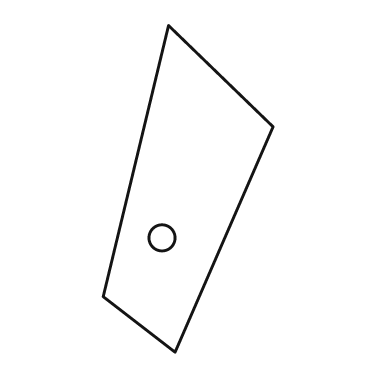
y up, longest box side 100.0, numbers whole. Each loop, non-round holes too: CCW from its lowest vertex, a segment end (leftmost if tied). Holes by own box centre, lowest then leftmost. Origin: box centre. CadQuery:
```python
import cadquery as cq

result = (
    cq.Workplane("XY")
    .moveTo(-4.0, -50.0)
    .lineTo(26.0, 19.0)
    .lineTo(-6.0, 50.0)
    .lineTo(-26.0, -33.0)
    .close()
    .moveTo(-8.0, -15.0)
    .circle(4.0)
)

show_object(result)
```